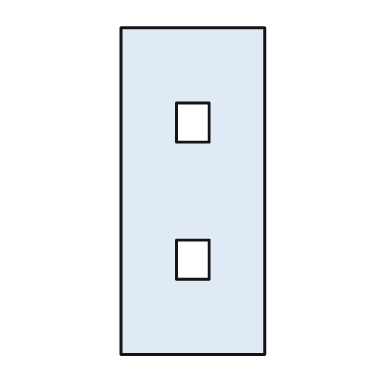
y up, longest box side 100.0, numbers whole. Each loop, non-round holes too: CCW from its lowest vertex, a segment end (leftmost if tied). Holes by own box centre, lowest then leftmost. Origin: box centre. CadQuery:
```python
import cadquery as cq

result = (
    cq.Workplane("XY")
    .moveTo(-22.0, -50.0)
    .lineTo(22.0, -50.0)
    .lineTo(22.0, 50.0)
    .lineTo(-22.0, 50.0)
    .close()
    .moveTo(-5.0, -27.0)
    .lineTo(5.0, -27.0)
    .lineTo(5.0, -15.0)
    .lineTo(-5.0, -15.0)
    .close()
    .moveTo(-5.0, 15.0)
    .lineTo(5.0, 15.0)
    .lineTo(5.0, 27.0)
    .lineTo(-5.0, 27.0)
    .close()
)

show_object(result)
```